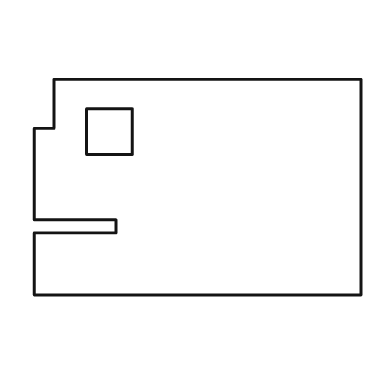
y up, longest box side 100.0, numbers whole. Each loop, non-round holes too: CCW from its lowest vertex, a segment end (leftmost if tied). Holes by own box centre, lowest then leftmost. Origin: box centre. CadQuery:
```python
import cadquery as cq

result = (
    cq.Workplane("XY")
    .moveTo(-50.0, -33.0)
    .lineTo(50.0, -33.0)
    .lineTo(50.0, 33.0)
    .lineTo(-44.0, 33.0)
    .lineTo(-44.0, 18.0)
    .lineTo(-50.0, 18.0)
    .lineTo(-50.0, -10.0)
    .lineTo(-25.0, -10.0)
    .lineTo(-25.0, -14.0)
    .lineTo(-50.0, -14.0)
    .close()
    .moveTo(-34.0, 10.0)
    .lineTo(-20.0, 10.0)
    .lineTo(-20.0, 24.0)
    .lineTo(-34.0, 24.0)
    .close()
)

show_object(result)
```